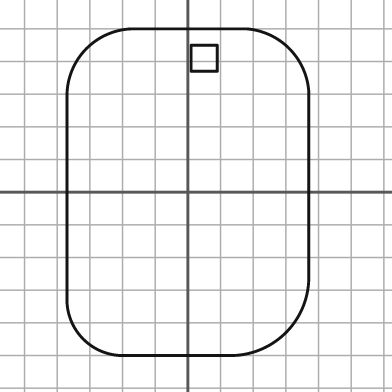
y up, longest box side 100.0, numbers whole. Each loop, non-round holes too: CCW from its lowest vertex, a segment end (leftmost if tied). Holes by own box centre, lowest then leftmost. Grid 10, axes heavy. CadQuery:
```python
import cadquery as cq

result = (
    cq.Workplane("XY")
    .moveTo(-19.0, -50.0)
    .lineTo(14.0, -50.0)
    .threePointArc((30.0, -43.0), (37.0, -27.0))
    .lineTo(37.0, 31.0)
    .threePointArc((31.0, 44.0), (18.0, 50.0))
    .lineTo(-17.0, 50.0)
    .threePointArc((-31.0, 44.0), (-37.0, 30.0))
    .lineTo(-37.0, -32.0)
    .threePointArc((-32.0, -45.0), (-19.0, -50.0))
    .close()
    .moveTo(1.0, 37.0)
    .lineTo(9.0, 37.0)
    .lineTo(9.0, 45.0)
    .lineTo(1.0, 45.0)
    .close()
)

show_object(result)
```